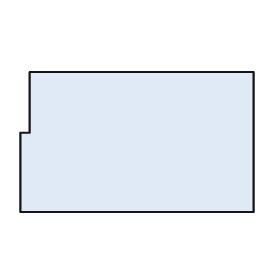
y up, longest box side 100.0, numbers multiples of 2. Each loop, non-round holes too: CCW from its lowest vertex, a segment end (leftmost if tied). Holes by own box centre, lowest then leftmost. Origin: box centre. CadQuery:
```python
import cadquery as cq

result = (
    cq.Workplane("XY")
    .moveTo(-50.0, -30.0)
    .lineTo(50.0, -30.0)
    .lineTo(50.0, 30.0)
    .lineTo(-46.0, 30.0)
    .lineTo(-46.0, 4.0)
    .lineTo(-50.0, 4.0)
    .close()
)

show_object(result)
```